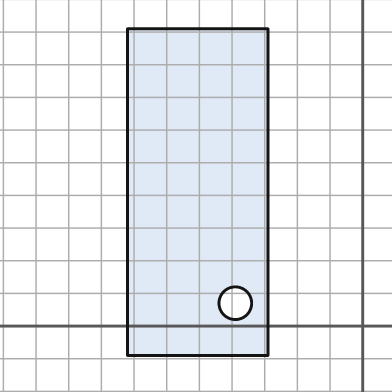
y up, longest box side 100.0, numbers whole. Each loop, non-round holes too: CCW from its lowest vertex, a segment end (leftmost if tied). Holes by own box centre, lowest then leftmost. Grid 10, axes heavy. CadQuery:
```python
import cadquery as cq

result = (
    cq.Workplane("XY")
    .moveTo(-72.0, -9.0)
    .lineTo(-29.0, -9.0)
    .lineTo(-29.0, 91.0)
    .lineTo(-72.0, 91.0)
    .close()
    .moveTo(-39.0, 7.0)
    .circle(5.0)
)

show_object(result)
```